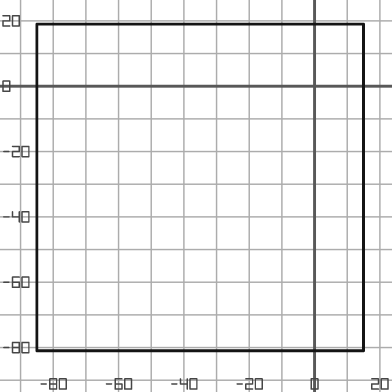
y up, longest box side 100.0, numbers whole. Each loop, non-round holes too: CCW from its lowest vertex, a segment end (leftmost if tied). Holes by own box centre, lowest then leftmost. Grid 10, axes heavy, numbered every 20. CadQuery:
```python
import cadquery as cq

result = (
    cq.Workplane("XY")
    .moveTo(-85.0, -81.0)
    .lineTo(15.0, -81.0)
    .lineTo(15.0, 19.0)
    .lineTo(-85.0, 19.0)
    .close()
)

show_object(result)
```